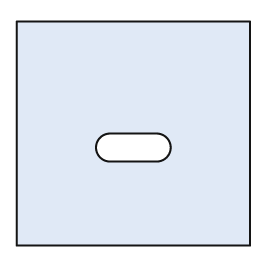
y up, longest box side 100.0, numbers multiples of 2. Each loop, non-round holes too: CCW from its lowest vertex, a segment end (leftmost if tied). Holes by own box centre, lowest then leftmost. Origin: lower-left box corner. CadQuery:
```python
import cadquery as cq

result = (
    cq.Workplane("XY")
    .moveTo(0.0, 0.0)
    .lineTo(100.0, 0.0)
    .lineTo(100.0, 96.0)
    .lineTo(0.0, 96.0)
    .close()
    .moveTo(40.0, 36.0)
    .lineTo(60.0, 36.0)
    .threePointArc((66.0, 42.0), (60.0, 48.0))
    .lineTo(40.0, 48.0)
    .threePointArc((34.0, 42.0), (40.0, 36.0))
    .close()
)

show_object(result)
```